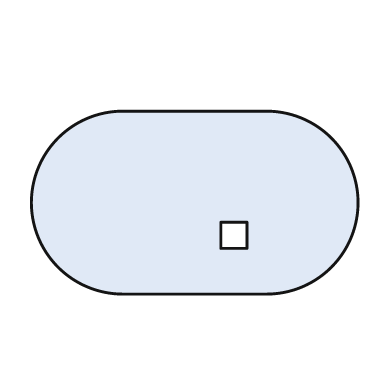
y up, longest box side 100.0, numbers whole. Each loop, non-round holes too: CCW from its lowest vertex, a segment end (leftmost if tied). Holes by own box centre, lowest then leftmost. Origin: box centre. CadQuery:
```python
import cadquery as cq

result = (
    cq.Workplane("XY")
    .moveTo(-22.0, -28.0)
    .lineTo(22.0, -28.0)
    .threePointArc((50.0, 0.0), (22.0, 28.0))
    .lineTo(-22.0, 28.0)
    .threePointArc((-50.0, 0.0), (-22.0, -28.0))
    .close()
    .moveTo(8.0, -14.0)
    .lineTo(16.0, -14.0)
    .lineTo(16.0, -6.0)
    .lineTo(8.0, -6.0)
    .close()
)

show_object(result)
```